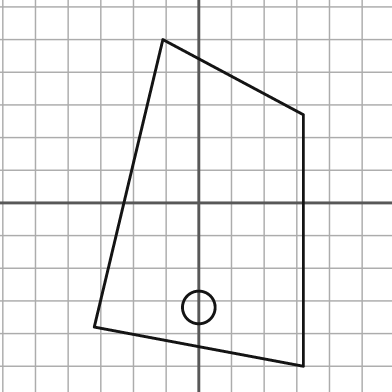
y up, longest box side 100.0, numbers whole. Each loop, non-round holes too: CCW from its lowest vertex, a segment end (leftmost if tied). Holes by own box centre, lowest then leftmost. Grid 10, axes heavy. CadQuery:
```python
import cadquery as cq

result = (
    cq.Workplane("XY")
    .moveTo(32.0, -50.0)
    .lineTo(32.0, 27.0)
    .lineTo(-11.0, 50.0)
    .lineTo(-32.0, -38.0)
    .close()
    .moveTo(0.0, -32.0)
    .circle(5.0)
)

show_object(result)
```